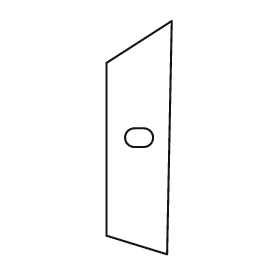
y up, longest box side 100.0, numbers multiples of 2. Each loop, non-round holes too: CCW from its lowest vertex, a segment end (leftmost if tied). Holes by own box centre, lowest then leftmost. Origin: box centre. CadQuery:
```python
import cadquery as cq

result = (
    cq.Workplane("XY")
    .moveTo(12.0, -50.0)
    .lineTo(14.0, 50.0)
    .lineTo(-14.0, 32.0)
    .lineTo(-14.0, -42.0)
    .close()
    .moveTo(-2.0, -4.0)
    .lineTo(2.0, -4.0)
    .threePointArc((6.0, 0.0), (2.0, 4.0))
    .lineTo(-2.0, 4.0)
    .threePointArc((-6.0, 0.0), (-2.0, -4.0))
    .close()
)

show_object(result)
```